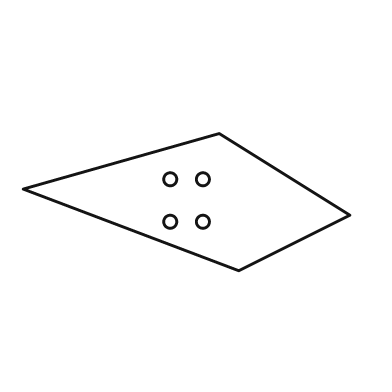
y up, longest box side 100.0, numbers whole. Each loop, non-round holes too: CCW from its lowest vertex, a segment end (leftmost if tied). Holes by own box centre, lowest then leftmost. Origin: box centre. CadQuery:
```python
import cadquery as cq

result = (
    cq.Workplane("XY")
    .moveTo(16.0, -21.0)
    .lineTo(50.0, -4.0)
    .lineTo(10.0, 21.0)
    .lineTo(-50.0, 4.0)
    .close()
    .moveTo(-5.0, -6.0)
    .circle(2.0)
    .moveTo(5.0, -6.0)
    .circle(2.0)
    .moveTo(-5.0, 7.0)
    .circle(2.0)
    .moveTo(5.0, 7.0)
    .circle(2.0)
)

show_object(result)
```